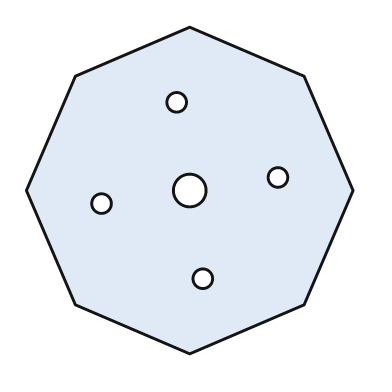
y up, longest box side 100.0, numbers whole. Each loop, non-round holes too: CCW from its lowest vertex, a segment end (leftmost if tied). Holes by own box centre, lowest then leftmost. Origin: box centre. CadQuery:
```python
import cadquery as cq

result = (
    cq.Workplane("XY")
    .moveTo(0.0, -50.0)
    .lineTo(35.0, -35.0)
    .lineTo(50.0, 0.0)
    .lineTo(35.0, 35.0)
    .lineTo(0.0, 50.0)
    .lineTo(-35.0, 35.0)
    .lineTo(-50.0, 0.0)
    .lineTo(-35.0, -35.0)
    .close()
    .moveTo(4.0, -27.0)
    .circle(3.0)
    .moveTo(-27.0, -4.0)
    .circle(3.0)
    .moveTo(0.0, 0.0)
    .circle(5.0)
    .moveTo(27.0, 4.0)
    .circle(3.0)
    .moveTo(-4.0, 27.0)
    .circle(3.0)
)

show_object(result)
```